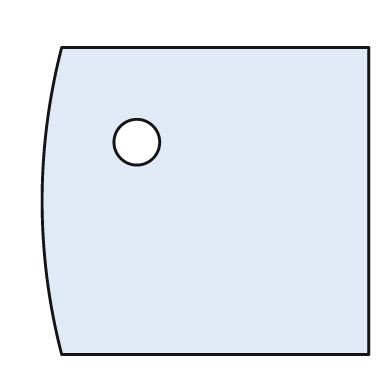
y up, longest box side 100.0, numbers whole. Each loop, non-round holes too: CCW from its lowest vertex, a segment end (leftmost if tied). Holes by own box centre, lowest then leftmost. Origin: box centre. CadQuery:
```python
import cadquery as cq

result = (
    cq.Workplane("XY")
    .moveTo(-44.0, -47.0)
    .lineTo(50.0, -47.0)
    .lineTo(50.0, 47.0)
    .lineTo(-44.0, 47.0)
    .threePointArc((-50.0, 0.0), (-44.0, -47.0))
    .close()
    .moveTo(-21.0, 18.0)
    .circle(7.0)
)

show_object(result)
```